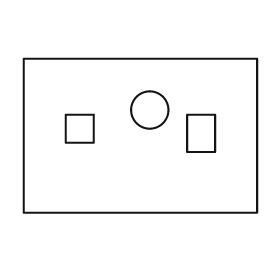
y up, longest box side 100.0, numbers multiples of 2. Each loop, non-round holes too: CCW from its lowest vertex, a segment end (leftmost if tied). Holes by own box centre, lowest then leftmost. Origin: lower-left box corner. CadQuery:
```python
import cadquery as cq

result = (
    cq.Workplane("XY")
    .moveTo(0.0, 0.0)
    .lineTo(100.0, 0.0)
    .lineTo(100.0, 66.0)
    .lineTo(0.0, 66.0)
    .close()
    .moveTo(70.0, 26.0)
    .lineTo(82.0, 26.0)
    .lineTo(82.0, 42.0)
    .lineTo(70.0, 42.0)
    .close()
    .moveTo(18.0, 30.0)
    .lineTo(30.0, 30.0)
    .lineTo(30.0, 42.0)
    .lineTo(18.0, 42.0)
    .close()
    .moveTo(54.0, 44.0)
    .circle(8.0)
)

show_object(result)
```